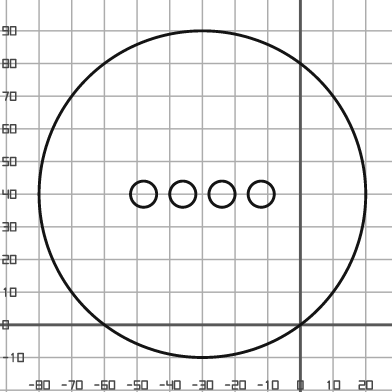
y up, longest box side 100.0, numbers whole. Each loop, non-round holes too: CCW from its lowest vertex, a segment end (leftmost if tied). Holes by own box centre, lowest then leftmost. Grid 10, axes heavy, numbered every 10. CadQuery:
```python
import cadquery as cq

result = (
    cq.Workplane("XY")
    .moveTo(-30.0, 40.0)
    .circle(50.0)
    .moveTo(-48.0, 40.0)
    .circle(4.0)
    .moveTo(-36.0, 40.0)
    .circle(4.0)
    .moveTo(-24.0, 40.0)
    .circle(4.0)
    .moveTo(-12.0, 40.0)
    .circle(4.0)
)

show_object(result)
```